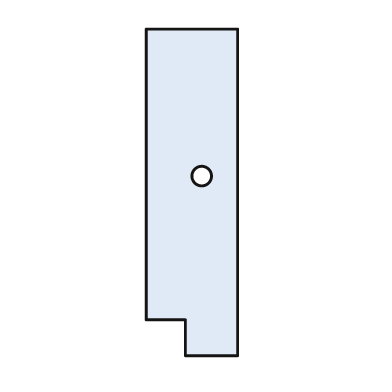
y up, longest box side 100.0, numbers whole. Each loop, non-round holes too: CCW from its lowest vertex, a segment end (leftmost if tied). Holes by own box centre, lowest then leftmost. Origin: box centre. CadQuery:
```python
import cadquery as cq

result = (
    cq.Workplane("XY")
    .moveTo(-2.0, -50.0)
    .lineTo(14.0, -50.0)
    .lineTo(14.0, 50.0)
    .lineTo(-14.0, 50.0)
    .lineTo(-14.0, -39.0)
    .lineTo(-2.0, -39.0)
    .close()
    .moveTo(3.0, 5.0)
    .circle(3.0)
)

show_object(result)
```